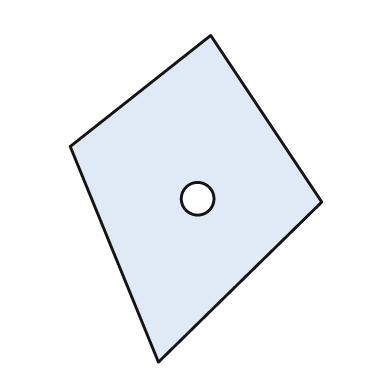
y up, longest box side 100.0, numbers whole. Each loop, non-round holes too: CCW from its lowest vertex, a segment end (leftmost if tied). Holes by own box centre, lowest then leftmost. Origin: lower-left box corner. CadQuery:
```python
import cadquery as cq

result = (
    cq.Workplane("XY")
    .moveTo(27.0, 0.0)
    .lineTo(77.0, 49.0)
    .lineTo(43.0, 100.0)
    .lineTo(0.0, 66.0)
    .close()
    .moveTo(39.0, 50.0)
    .circle(5.0)
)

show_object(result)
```